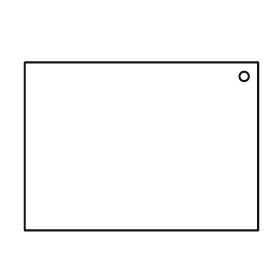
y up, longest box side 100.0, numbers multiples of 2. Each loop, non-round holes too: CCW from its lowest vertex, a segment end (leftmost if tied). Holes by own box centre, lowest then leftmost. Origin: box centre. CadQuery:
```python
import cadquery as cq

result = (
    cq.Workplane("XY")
    .moveTo(-50.0, -36.0)
    .lineTo(50.0, -36.0)
    .lineTo(50.0, 36.0)
    .lineTo(-50.0, 36.0)
    .close()
    .moveTo(44.0, 30.0)
    .circle(2.0)
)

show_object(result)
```